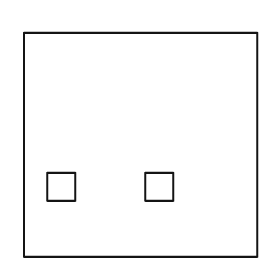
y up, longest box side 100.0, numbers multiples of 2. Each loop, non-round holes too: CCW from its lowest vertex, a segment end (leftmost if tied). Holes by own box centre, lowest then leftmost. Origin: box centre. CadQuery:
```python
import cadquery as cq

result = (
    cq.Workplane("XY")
    .moveTo(-50.0, -48.0)
    .lineTo(50.0, -48.0)
    .lineTo(50.0, 48.0)
    .lineTo(-50.0, 48.0)
    .close()
    .moveTo(-40.0, -24.0)
    .lineTo(-28.0, -24.0)
    .lineTo(-28.0, -12.0)
    .lineTo(-40.0, -12.0)
    .close()
    .moveTo(2.0, -24.0)
    .lineTo(14.0, -24.0)
    .lineTo(14.0, -12.0)
    .lineTo(2.0, -12.0)
    .close()
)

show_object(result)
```